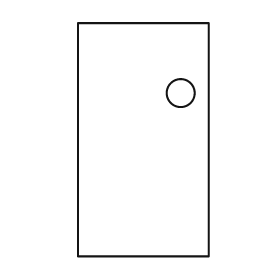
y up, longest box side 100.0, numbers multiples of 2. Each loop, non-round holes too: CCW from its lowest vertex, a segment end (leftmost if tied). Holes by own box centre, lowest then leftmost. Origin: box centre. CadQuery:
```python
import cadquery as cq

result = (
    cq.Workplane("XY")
    .moveTo(-28.0, -50.0)
    .lineTo(28.0, -50.0)
    .lineTo(28.0, 50.0)
    .lineTo(-28.0, 50.0)
    .close()
    .moveTo(16.0, 20.0)
    .circle(6.0)
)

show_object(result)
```